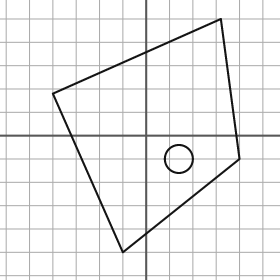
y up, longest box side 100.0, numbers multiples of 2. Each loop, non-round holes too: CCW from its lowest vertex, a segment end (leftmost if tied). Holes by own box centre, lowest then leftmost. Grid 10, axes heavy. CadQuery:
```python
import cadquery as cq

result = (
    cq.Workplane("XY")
    .moveTo(-10.0, -50.0)
    .lineTo(40.0, -10.0)
    .lineTo(32.0, 50.0)
    .lineTo(-40.0, 18.0)
    .close()
    .moveTo(14.0, -10.0)
    .circle(6.0)
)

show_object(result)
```